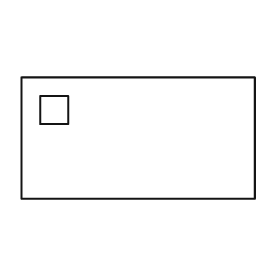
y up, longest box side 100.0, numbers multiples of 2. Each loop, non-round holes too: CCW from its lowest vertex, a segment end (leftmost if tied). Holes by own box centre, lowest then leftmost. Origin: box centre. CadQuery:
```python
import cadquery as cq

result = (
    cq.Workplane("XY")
    .moveTo(-50.0, -26.0)
    .lineTo(50.0, -26.0)
    .lineTo(50.0, 26.0)
    .lineTo(-50.0, 26.0)
    .close()
    .moveTo(-42.0, 6.0)
    .lineTo(-30.0, 6.0)
    .lineTo(-30.0, 18.0)
    .lineTo(-42.0, 18.0)
    .close()
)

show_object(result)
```